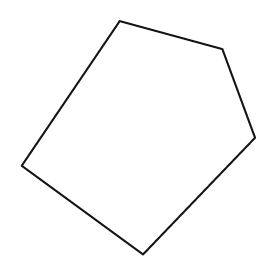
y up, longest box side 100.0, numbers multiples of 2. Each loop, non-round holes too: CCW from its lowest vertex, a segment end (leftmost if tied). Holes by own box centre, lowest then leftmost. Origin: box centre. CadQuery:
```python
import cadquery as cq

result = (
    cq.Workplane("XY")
    .moveTo(2.0, -50.0)
    .lineTo(50.0, 0.0)
    .lineTo(36.0, 38.0)
    .lineTo(-8.0, 50.0)
    .lineTo(-50.0, -12.0)
    .close()
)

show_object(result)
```